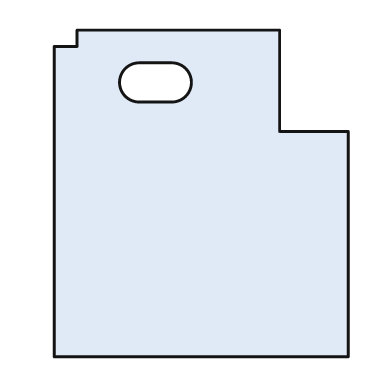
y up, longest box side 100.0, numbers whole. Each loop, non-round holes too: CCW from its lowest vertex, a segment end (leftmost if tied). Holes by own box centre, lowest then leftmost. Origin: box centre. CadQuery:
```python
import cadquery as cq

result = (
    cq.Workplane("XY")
    .moveTo(-45.0, -50.0)
    .lineTo(45.0, -50.0)
    .lineTo(45.0, 19.0)
    .lineTo(24.0, 19.0)
    .lineTo(24.0, 50.0)
    .lineTo(-38.0, 50.0)
    .lineTo(-38.0, 45.0)
    .lineTo(-45.0, 45.0)
    .close()
    .moveTo(-19.0, 28.0)
    .lineTo(-9.0, 28.0)
    .threePointArc((-3.0, 34.0), (-9.0, 40.0))
    .lineTo(-19.0, 40.0)
    .threePointArc((-25.0, 34.0), (-19.0, 28.0))
    .close()
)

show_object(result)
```